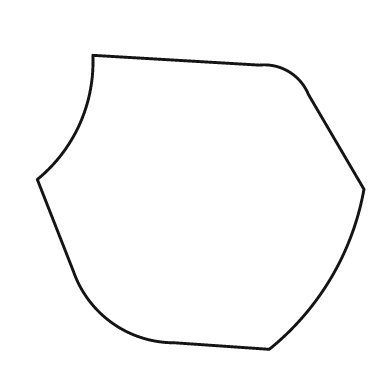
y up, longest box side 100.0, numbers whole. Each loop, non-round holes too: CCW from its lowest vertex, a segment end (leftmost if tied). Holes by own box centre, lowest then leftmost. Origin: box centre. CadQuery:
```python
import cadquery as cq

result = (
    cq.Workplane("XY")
    .moveTo(21.0, -45.0)
    .threePointArc((40.0, -23.0), (50.0, 4.0))
    .lineTo(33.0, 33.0)
    .threePointArc((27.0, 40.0), (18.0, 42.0))
    .lineTo(-33.0, 45.0)
    .threePointArc((-37.0, 24.0), (-50.0, 7.0))
    .lineTo(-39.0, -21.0)
    .threePointArc((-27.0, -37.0), (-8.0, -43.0))
    .close()
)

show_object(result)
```